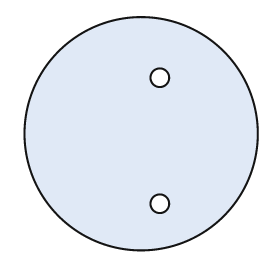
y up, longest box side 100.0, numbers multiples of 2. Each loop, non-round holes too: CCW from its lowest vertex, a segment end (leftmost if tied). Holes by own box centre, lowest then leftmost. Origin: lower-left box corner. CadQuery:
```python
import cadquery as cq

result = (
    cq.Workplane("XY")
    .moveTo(50.0, 50.0)
    .circle(50.0)
    .moveTo(58.0, 20.0)
    .circle(4.0)
    .moveTo(58.0, 74.0)
    .circle(4.0)
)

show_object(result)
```